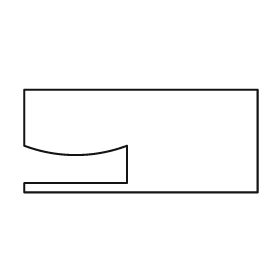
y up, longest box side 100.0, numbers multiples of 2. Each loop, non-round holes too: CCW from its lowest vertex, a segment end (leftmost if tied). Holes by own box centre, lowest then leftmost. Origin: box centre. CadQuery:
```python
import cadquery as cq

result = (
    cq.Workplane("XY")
    .moveTo(-50.0, -22.0)
    .lineTo(50.0, -22.0)
    .lineTo(50.0, 22.0)
    .lineTo(-50.0, 22.0)
    .lineTo(-50.0, -2.0)
    .threePointArc((-28.0, -6.0), (-6.0, -2.0))
    .lineTo(-6.0, -18.0)
    .lineTo(-50.0, -18.0)
    .close()
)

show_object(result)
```